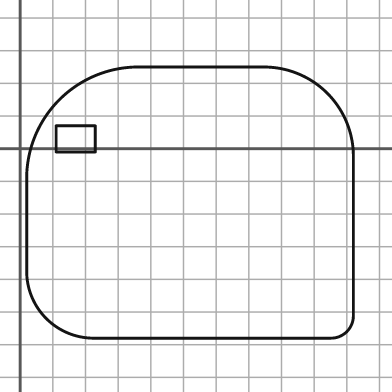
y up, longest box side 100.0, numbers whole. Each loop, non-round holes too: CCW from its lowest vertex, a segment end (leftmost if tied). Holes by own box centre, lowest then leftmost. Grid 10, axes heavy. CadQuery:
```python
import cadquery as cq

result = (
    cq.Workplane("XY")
    .moveTo(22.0, -58.0)
    .lineTo(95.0, -58.0)
    .threePointArc((100.0, -56.0), (102.0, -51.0))
    .lineTo(102.0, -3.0)
    .threePointArc((94.0, 17.0), (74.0, 25.0))
    .lineTo(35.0, 25.0)
    .threePointArc((12.0, 15.0), (2.0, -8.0))
    .lineTo(2.0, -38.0)
    .threePointArc((8.0, -52.0), (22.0, -58.0))
    .close()
    .moveTo(11.0, -1.0)
    .lineTo(23.0, -1.0)
    .lineTo(23.0, 7.0)
    .lineTo(11.0, 7.0)
    .close()
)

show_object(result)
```